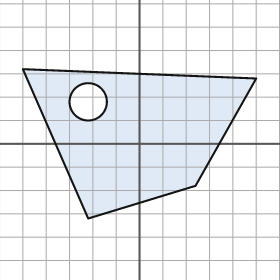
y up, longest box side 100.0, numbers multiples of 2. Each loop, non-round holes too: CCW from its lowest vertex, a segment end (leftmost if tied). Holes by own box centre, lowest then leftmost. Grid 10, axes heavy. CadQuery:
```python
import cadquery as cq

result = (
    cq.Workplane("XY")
    .moveTo(-22.0, -32.0)
    .lineTo(24.0, -18.0)
    .lineTo(50.0, 28.0)
    .lineTo(-50.0, 32.0)
    .close()
    .moveTo(-22.0, 18.0)
    .circle(8.0)
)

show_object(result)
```